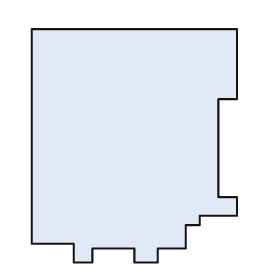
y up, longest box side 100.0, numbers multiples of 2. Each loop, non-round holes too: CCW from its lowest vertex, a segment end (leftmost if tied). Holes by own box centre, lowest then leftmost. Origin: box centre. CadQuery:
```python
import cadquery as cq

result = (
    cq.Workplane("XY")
    .moveTo(-26.0, -50.0)
    .lineTo(-18.0, -50.0)
    .lineTo(-18.0, -44.0)
    .lineTo(0.0, -44.0)
    .lineTo(0.0, -50.0)
    .lineTo(10.0, -50.0)
    .lineTo(10.0, -44.0)
    .lineTo(22.0, -44.0)
    .lineTo(22.0, -34.0)
    .lineTo(28.0, -34.0)
    .lineTo(28.0, -30.0)
    .lineTo(44.0, -30.0)
    .lineTo(44.0, -22.0)
    .lineTo(36.0, -22.0)
    .lineTo(36.0, 20.0)
    .lineTo(44.0, 20.0)
    .lineTo(44.0, 50.0)
    .lineTo(-44.0, 50.0)
    .lineTo(-44.0, -42.0)
    .lineTo(-26.0, -42.0)
    .close()
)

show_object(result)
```